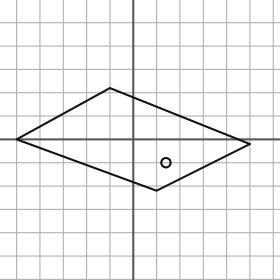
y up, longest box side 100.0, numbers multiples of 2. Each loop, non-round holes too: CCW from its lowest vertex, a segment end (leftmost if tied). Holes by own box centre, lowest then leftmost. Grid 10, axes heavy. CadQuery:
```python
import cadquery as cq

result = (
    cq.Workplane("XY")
    .moveTo(10.0, -22.0)
    .lineTo(50.0, -2.0)
    .lineTo(-10.0, 22.0)
    .lineTo(-50.0, 0.0)
    .close()
    .moveTo(14.0, -10.0)
    .circle(2.0)
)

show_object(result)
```